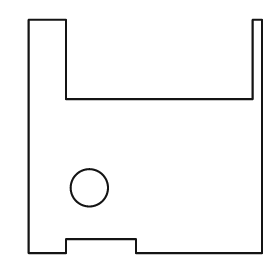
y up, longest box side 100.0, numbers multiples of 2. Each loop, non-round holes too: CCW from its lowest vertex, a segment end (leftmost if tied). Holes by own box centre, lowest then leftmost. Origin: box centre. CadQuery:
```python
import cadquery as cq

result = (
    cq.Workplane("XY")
    .moveTo(-50.0, -50.0)
    .lineTo(-34.0, -50.0)
    .lineTo(-34.0, -44.0)
    .lineTo(-4.0, -44.0)
    .lineTo(-4.0, -50.0)
    .lineTo(50.0, -50.0)
    .lineTo(50.0, 50.0)
    .lineTo(46.0, 50.0)
    .lineTo(46.0, 16.0)
    .lineTo(-34.0, 16.0)
    .lineTo(-34.0, 50.0)
    .lineTo(-50.0, 50.0)
    .close()
    .moveTo(-24.0, -22.0)
    .circle(8.0)
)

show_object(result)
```